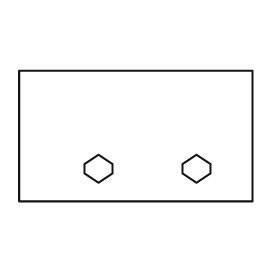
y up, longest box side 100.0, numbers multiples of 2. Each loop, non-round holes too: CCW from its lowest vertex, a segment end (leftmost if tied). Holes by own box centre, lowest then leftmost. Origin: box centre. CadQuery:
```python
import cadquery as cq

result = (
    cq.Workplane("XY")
    .moveTo(-50.0, -28.0)
    .lineTo(50.0, -28.0)
    .lineTo(50.0, 28.0)
    .lineTo(-50.0, 28.0)
    .close()
    .moveTo(-16.0, -20.0)
    .lineTo(-10.0, -16.0)
    .lineTo(-10.0, -12.0)
    .lineTo(-16.0, -8.0)
    .lineTo(-22.0, -12.0)
    .lineTo(-22.0, -16.0)
    .close()
    .moveTo(26.0, -20.0)
    .lineTo(32.0, -16.0)
    .lineTo(32.0, -12.0)
    .lineTo(26.0, -8.0)
    .lineTo(20.0, -12.0)
    .lineTo(20.0, -16.0)
    .close()
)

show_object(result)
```